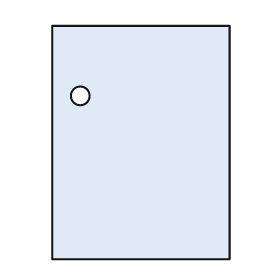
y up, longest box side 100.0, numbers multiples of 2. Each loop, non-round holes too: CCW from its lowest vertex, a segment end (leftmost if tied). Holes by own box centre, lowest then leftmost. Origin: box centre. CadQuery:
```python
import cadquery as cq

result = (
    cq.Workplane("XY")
    .moveTo(-38.0, -50.0)
    .lineTo(38.0, -50.0)
    .lineTo(38.0, 50.0)
    .lineTo(-38.0, 50.0)
    .close()
    .moveTo(-26.0, 20.0)
    .circle(4.0)
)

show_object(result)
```